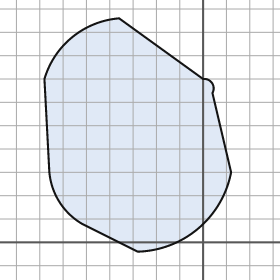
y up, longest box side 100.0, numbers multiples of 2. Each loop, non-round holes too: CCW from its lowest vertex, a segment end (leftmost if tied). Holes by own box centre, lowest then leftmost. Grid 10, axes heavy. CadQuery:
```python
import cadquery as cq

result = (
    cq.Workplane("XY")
    .moveTo(-28.0, -4.0)
    .threePointArc((-2.0, 6.0), (12.0, 30.0))
    .lineTo(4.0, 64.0)
    .threePointArc((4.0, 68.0), (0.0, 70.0))
    .lineTo(-36.0, 96.0)
    .threePointArc((-56.0, 88.0), (-68.0, 70.0))
    .lineTo(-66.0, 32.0)
    .threePointArc((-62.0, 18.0), (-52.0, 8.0))
    .close()
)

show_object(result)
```